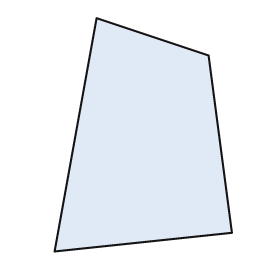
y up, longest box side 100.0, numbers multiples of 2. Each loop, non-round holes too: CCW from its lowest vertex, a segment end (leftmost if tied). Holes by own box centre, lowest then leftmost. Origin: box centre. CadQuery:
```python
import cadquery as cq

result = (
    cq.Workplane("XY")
    .moveTo(-38.0, -50.0)
    .lineTo(38.0, -42.0)
    .lineTo(28.0, 34.0)
    .lineTo(-20.0, 50.0)
    .close()
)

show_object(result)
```